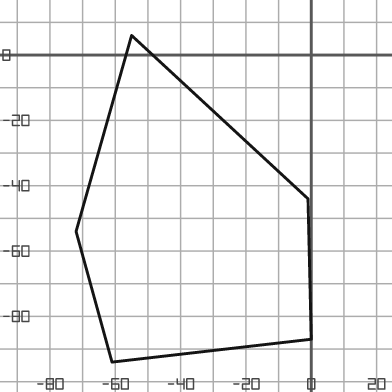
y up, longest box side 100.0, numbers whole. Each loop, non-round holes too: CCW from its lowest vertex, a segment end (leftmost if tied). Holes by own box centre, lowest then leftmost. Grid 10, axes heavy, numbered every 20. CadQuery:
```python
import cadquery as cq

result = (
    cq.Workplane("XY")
    .moveTo(-61.0, -94.0)
    .lineTo(0.0, -87.0)
    .lineTo(-1.0, -44.0)
    .lineTo(-55.0, 6.0)
    .lineTo(-72.0, -54.0)
    .close()
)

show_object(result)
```